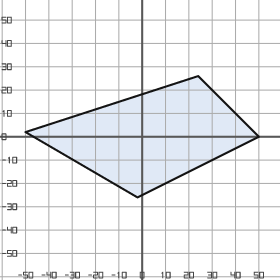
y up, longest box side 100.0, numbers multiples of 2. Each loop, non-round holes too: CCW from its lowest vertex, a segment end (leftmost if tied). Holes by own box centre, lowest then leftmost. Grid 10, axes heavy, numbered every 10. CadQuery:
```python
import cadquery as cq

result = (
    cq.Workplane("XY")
    .moveTo(-2.0, -26.0)
    .lineTo(50.0, 0.0)
    .lineTo(24.0, 26.0)
    .lineTo(-50.0, 2.0)
    .close()
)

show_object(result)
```